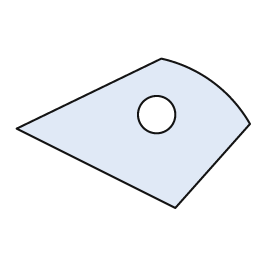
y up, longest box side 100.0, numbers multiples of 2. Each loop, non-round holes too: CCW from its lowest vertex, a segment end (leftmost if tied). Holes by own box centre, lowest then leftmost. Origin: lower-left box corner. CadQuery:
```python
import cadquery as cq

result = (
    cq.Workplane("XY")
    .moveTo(68.0, 0.0)
    .lineTo(100.0, 36.0)
    .threePointArc((84.0, 54.0), (62.0, 64.0))
    .lineTo(0.0, 34.0)
    .close()
    .moveTo(60.0, 40.0)
    .circle(8.0)
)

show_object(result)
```